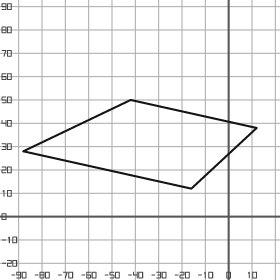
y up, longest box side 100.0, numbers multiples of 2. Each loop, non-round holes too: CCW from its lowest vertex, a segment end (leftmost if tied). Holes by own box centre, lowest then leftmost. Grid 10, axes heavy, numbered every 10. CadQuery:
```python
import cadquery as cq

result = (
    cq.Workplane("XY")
    .moveTo(-16.0, 12.0)
    .lineTo(12.0, 38.0)
    .lineTo(-42.0, 50.0)
    .lineTo(-88.0, 28.0)
    .close()
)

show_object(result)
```